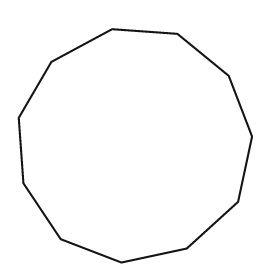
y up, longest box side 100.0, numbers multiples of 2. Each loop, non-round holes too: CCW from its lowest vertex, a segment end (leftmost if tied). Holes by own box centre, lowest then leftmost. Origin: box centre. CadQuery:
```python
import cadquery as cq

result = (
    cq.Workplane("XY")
    .moveTo(-6.0, -50.0)
    .lineTo(22.0, -44.0)
    .lineTo(44.0, -24.0)
    .lineTo(50.0, 4.0)
    .lineTo(40.0, 30.0)
    .lineTo(18.0, 48.0)
    .lineTo(-10.0, 50.0)
    .lineTo(-36.0, 36.0)
    .lineTo(-50.0, 12.0)
    .lineTo(-48.0, -16.0)
    .lineTo(-32.0, -40.0)
    .close()
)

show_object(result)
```